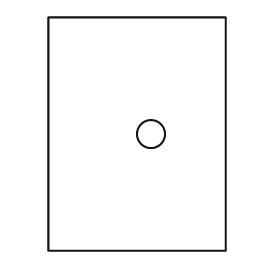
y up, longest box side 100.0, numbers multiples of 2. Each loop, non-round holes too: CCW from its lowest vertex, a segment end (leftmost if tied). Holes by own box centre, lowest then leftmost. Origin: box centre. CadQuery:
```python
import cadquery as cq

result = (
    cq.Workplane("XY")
    .moveTo(-38.0, -50.0)
    .lineTo(38.0, -50.0)
    .lineTo(38.0, 50.0)
    .lineTo(-38.0, 50.0)
    .close()
    .moveTo(6.0, 0.0)
    .circle(6.0)
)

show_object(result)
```